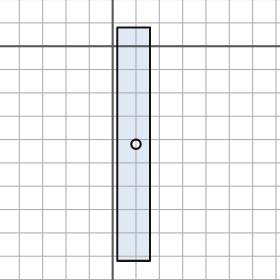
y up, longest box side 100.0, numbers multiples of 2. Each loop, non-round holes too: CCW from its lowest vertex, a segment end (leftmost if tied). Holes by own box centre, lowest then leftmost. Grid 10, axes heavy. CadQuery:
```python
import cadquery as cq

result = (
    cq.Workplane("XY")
    .moveTo(2.0, -92.0)
    .lineTo(16.0, -92.0)
    .lineTo(16.0, 8.0)
    .lineTo(2.0, 8.0)
    .close()
    .moveTo(10.0, -42.0)
    .circle(2.0)
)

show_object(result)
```